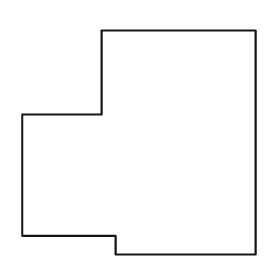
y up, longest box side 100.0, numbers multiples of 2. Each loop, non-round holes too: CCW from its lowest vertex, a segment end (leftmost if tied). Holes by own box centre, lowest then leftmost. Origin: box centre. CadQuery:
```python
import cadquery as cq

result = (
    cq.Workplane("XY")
    .moveTo(-10.0, -48.0)
    .lineTo(50.0, -48.0)
    .lineTo(50.0, 48.0)
    .lineTo(-16.0, 48.0)
    .lineTo(-16.0, 12.0)
    .lineTo(-50.0, 12.0)
    .lineTo(-50.0, -40.0)
    .lineTo(-10.0, -40.0)
    .close()
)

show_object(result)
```